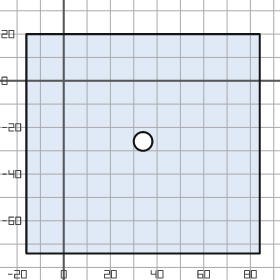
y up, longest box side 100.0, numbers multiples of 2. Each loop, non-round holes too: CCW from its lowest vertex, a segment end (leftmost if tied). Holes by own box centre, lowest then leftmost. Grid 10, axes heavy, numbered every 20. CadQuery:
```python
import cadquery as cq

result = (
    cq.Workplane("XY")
    .moveTo(-16.0, -74.0)
    .lineTo(84.0, -74.0)
    .lineTo(84.0, 20.0)
    .lineTo(-16.0, 20.0)
    .close()
    .moveTo(34.0, -26.0)
    .circle(4.0)
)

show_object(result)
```